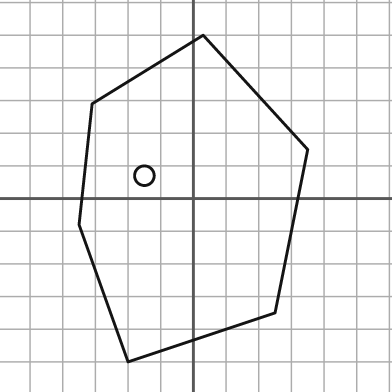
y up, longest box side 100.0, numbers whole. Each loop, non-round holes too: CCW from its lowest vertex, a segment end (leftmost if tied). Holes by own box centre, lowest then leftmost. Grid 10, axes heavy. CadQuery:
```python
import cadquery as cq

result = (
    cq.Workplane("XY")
    .moveTo(-20.0, -50.0)
    .lineTo(25.0, -35.0)
    .lineTo(35.0, 15.0)
    .lineTo(3.0, 50.0)
    .lineTo(-31.0, 29.0)
    .lineTo(-35.0, -8.0)
    .close()
    .moveTo(-15.0, 7.0)
    .circle(3.0)
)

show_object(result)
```